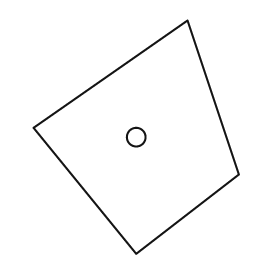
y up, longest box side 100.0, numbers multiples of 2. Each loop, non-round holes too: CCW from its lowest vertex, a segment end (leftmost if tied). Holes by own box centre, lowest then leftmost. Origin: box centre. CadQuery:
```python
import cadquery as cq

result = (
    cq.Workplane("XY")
    .moveTo(0.0, -50.0)
    .lineTo(44.0, -16.0)
    .lineTo(22.0, 50.0)
    .lineTo(-44.0, 4.0)
    .close()
    .moveTo(0.0, 0.0)
    .circle(4.0)
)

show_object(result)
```